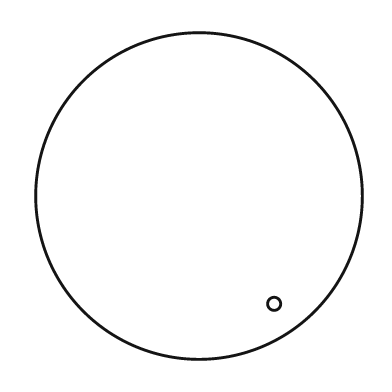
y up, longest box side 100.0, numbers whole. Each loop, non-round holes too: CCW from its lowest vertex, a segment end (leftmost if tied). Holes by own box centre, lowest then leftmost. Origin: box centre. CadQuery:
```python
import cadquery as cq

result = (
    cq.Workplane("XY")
    .moveTo(0.0, 0.0)
    .circle(50.0)
    .moveTo(23.0, -33.0)
    .circle(2.0)
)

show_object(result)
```